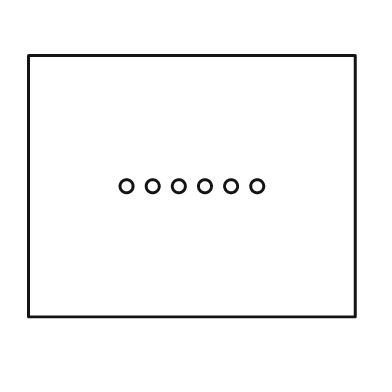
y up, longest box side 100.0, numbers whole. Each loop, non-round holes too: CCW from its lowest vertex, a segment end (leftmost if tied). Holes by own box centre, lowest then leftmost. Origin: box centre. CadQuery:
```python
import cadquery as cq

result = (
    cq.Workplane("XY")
    .moveTo(-50.0, -40.0)
    .lineTo(50.0, -40.0)
    .lineTo(50.0, 40.0)
    .lineTo(-50.0, 40.0)
    .close()
    .moveTo(-20.0, 0.0)
    .circle(2.0)
    .moveTo(-12.0, 0.0)
    .circle(2.0)
    .moveTo(-4.0, 0.0)
    .circle(2.0)
    .moveTo(4.0, 0.0)
    .circle(2.0)
    .moveTo(12.0, 0.0)
    .circle(2.0)
    .moveTo(20.0, 0.0)
    .circle(2.0)
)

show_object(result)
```